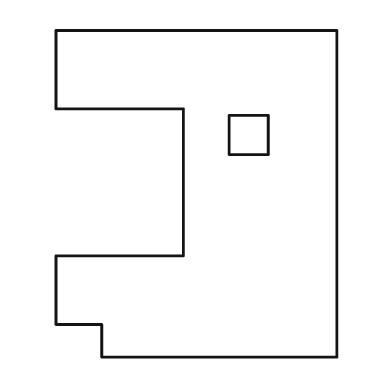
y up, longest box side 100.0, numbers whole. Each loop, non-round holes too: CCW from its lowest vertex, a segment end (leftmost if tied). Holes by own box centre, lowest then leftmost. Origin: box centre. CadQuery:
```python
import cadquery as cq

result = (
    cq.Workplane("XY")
    .moveTo(-29.0, -50.0)
    .lineTo(43.0, -50.0)
    .lineTo(43.0, 50.0)
    .lineTo(-43.0, 50.0)
    .lineTo(-43.0, 26.0)
    .lineTo(-4.0, 26.0)
    .lineTo(-4.0, -19.0)
    .lineTo(-43.0, -19.0)
    .lineTo(-43.0, -40.0)
    .lineTo(-29.0, -40.0)
    .close()
    .moveTo(10.0, 12.0)
    .lineTo(22.0, 12.0)
    .lineTo(22.0, 24.0)
    .lineTo(10.0, 24.0)
    .close()
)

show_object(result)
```